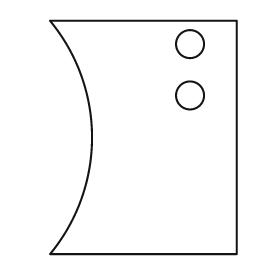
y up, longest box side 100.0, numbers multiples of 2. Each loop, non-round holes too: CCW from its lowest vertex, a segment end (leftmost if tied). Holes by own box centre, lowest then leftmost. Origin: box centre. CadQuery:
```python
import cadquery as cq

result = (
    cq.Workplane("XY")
    .moveTo(-40.0, -50.0)
    .lineTo(40.0, -50.0)
    .lineTo(40.0, 50.0)
    .lineTo(-40.0, 50.0)
    .threePointArc((-22.0, 0.0), (-40.0, -50.0))
    .close()
    .moveTo(20.0, 18.0)
    .circle(6.0)
    .moveTo(20.0, 40.0)
    .circle(6.0)
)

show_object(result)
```